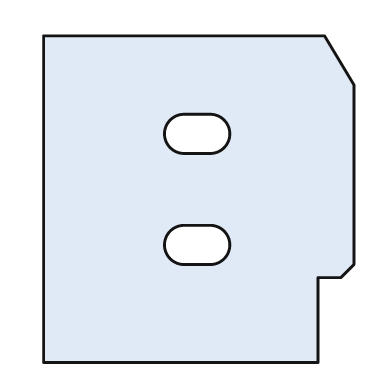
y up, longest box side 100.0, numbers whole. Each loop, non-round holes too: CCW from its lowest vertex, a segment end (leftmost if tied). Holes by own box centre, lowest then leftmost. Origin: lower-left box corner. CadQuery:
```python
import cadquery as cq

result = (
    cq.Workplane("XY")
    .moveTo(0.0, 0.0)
    .lineTo(84.0, 0.0)
    .lineTo(84.0, 26.0)
    .lineTo(91.0, 26.0)
    .lineTo(95.0, 30.0)
    .lineTo(95.0, 85.0)
    .lineTo(86.0, 100.0)
    .lineTo(0.0, 100.0)
    .close()
    .moveTo(43.0, 30.0)
    .lineTo(51.0, 30.0)
    .threePointArc((57.0, 36.0), (51.0, 42.0))
    .lineTo(43.0, 42.0)
    .threePointArc((37.0, 36.0), (43.0, 30.0))
    .close()
    .moveTo(43.0, 64.0)
    .lineTo(51.0, 64.0)
    .threePointArc((57.0, 70.0), (51.0, 76.0))
    .lineTo(43.0, 76.0)
    .threePointArc((37.0, 70.0), (43.0, 64.0))
    .close()
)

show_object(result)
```